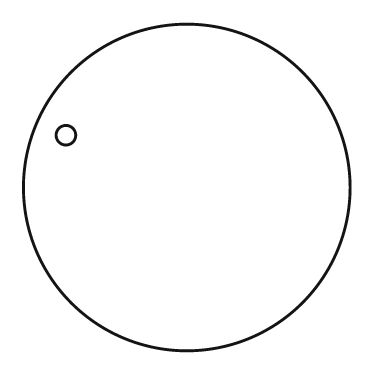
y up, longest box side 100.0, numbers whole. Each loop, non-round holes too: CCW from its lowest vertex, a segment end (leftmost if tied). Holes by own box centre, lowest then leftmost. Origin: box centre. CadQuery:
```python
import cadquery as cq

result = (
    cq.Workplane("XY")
    .moveTo(0.0, 0.0)
    .circle(50.0)
    .moveTo(-37.0, 16.0)
    .circle(3.0)
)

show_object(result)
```